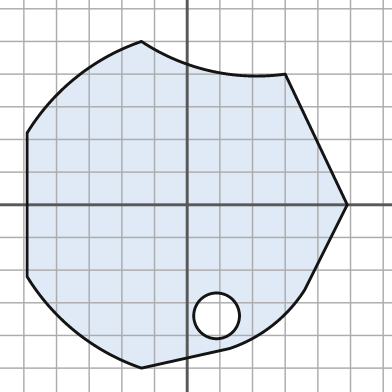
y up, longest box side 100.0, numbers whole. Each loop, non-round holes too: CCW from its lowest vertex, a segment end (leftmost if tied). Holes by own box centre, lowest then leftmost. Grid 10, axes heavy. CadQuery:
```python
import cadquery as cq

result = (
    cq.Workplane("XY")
    .moveTo(-14.0, -50.0)
    .lineTo(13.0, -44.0)
    .threePointArc((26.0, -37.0), (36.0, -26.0))
    .lineTo(49.0, 0.0)
    .lineTo(30.0, 40.0)
    .threePointArc((7.0, 41.0), (-14.0, 50.0))
    .threePointArc((-34.0, 39.0), (-49.0, 22.0))
    .lineTo(-49.0, -22.0)
    .threePointArc((-34.0, -39.0), (-14.0, -50.0))
    .close()
    .moveTo(9.0, -34.0)
    .circle(7.0)
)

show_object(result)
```